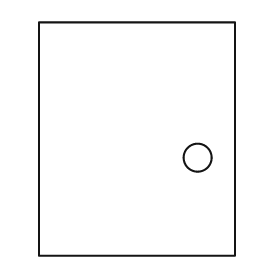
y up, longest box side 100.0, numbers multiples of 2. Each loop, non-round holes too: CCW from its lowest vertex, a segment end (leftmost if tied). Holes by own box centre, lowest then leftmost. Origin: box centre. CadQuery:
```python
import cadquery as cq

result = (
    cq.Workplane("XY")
    .moveTo(-42.0, -50.0)
    .lineTo(42.0, -50.0)
    .lineTo(42.0, 50.0)
    .lineTo(-42.0, 50.0)
    .close()
    .moveTo(26.0, -8.0)
    .circle(6.0)
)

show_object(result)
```